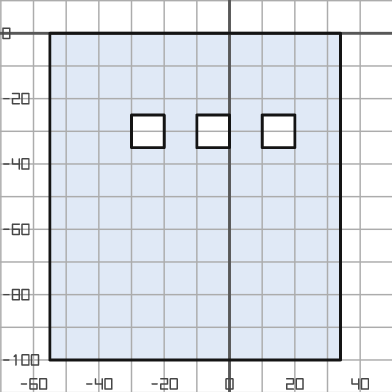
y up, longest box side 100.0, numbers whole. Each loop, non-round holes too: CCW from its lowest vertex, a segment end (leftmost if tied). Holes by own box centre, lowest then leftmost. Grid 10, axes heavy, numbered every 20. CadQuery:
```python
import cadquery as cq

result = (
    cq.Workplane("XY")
    .moveTo(-55.0, -100.0)
    .lineTo(34.0, -100.0)
    .lineTo(34.0, 0.0)
    .lineTo(-55.0, 0.0)
    .close()
    .moveTo(-30.0, -35.0)
    .lineTo(-20.0, -35.0)
    .lineTo(-20.0, -25.0)
    .lineTo(-30.0, -25.0)
    .close()
    .moveTo(-10.0, -35.0)
    .lineTo(0.0, -35.0)
    .lineTo(0.0, -25.0)
    .lineTo(-10.0, -25.0)
    .close()
    .moveTo(10.0, -35.0)
    .lineTo(20.0, -35.0)
    .lineTo(20.0, -25.0)
    .lineTo(10.0, -25.0)
    .close()
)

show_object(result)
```